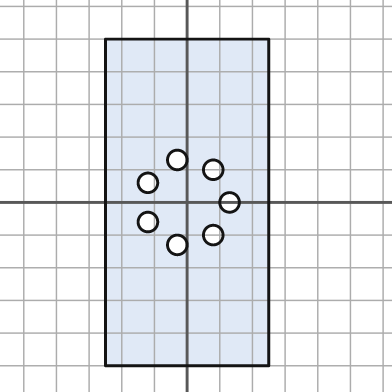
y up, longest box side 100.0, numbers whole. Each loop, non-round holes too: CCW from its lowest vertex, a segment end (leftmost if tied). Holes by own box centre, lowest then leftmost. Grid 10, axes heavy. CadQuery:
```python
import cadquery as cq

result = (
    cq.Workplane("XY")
    .moveTo(-25.0, -50.0)
    .lineTo(25.0, -50.0)
    .lineTo(25.0, 50.0)
    .lineTo(-25.0, 50.0)
    .close()
    .moveTo(-3.0, -13.0)
    .circle(3.0)
    .moveTo(8.0, -10.0)
    .circle(3.0)
    .moveTo(-12.0, -6.0)
    .circle(3.0)
    .moveTo(13.0, 0.0)
    .circle(3.0)
    .moveTo(-12.0, 6.0)
    .circle(3.0)
    .moveTo(8.0, 10.0)
    .circle(3.0)
    .moveTo(-3.0, 13.0)
    .circle(3.0)
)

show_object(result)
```